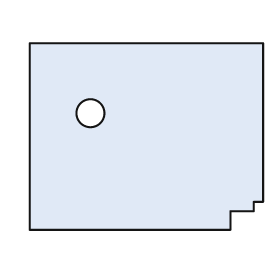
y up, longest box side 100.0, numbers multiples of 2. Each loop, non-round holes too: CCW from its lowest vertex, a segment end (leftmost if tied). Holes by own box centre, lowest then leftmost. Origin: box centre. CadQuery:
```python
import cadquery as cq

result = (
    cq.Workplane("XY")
    .moveTo(-50.0, -40.0)
    .lineTo(36.0, -40.0)
    .lineTo(36.0, -32.0)
    .lineTo(46.0, -32.0)
    .lineTo(46.0, -28.0)
    .lineTo(50.0, -28.0)
    .lineTo(50.0, 40.0)
    .lineTo(-50.0, 40.0)
    .close()
    .moveTo(-24.0, 10.0)
    .circle(6.0)
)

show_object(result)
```